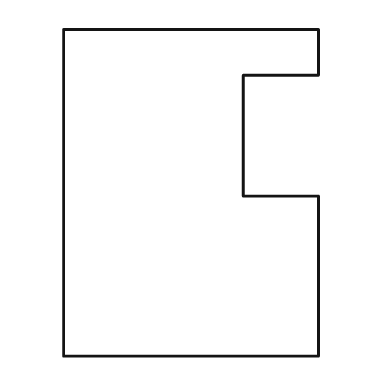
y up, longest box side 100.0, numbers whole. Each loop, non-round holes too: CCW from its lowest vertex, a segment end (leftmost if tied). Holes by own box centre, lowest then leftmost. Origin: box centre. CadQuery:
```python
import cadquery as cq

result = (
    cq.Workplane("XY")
    .moveTo(-39.0, -50.0)
    .lineTo(39.0, -50.0)
    .lineTo(39.0, -1.0)
    .lineTo(16.0, -1.0)
    .lineTo(16.0, 36.0)
    .lineTo(39.0, 36.0)
    .lineTo(39.0, 50.0)
    .lineTo(-39.0, 50.0)
    .close()
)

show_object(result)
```